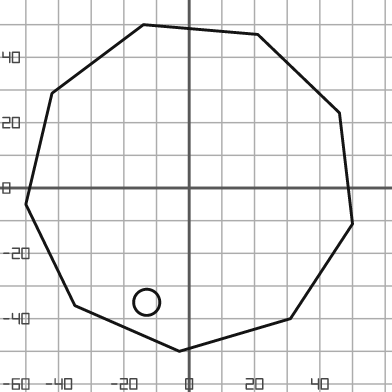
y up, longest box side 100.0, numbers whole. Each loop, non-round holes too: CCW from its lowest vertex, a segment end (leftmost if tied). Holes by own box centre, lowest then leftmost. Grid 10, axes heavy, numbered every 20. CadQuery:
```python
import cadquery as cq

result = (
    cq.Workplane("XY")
    .moveTo(-3.0, -50.0)
    .lineTo(31.0, -40.0)
    .lineTo(50.0, -11.0)
    .lineTo(46.0, 23.0)
    .lineTo(21.0, 47.0)
    .lineTo(-14.0, 50.0)
    .lineTo(-42.0, 29.0)
    .lineTo(-50.0, -5.0)
    .lineTo(-35.0, -36.0)
    .close()
    .moveTo(-13.0, -35.0)
    .circle(4.0)
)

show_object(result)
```